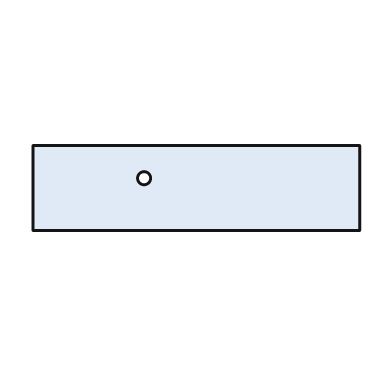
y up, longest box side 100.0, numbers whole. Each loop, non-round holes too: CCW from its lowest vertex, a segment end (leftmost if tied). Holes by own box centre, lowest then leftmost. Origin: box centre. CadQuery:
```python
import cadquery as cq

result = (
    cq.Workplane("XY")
    .moveTo(-50.0, -13.0)
    .lineTo(50.0, -13.0)
    .lineTo(50.0, 13.0)
    .lineTo(-50.0, 13.0)
    .close()
    .moveTo(-16.0, 3.0)
    .circle(2.0)
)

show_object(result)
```